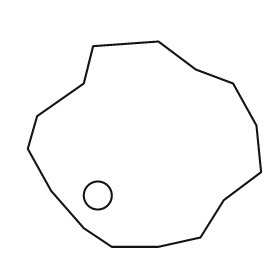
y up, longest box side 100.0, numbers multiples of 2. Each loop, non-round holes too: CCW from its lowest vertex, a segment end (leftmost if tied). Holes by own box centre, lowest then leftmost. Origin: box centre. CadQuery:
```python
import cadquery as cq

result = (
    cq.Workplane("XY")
    .moveTo(-14.0, -44.0)
    .lineTo(6.0, -44.0)
    .lineTo(24.0, -40.0)
    .lineTo(34.0, -24.0)
    .lineTo(50.0, -12.0)
    .lineTo(48.0, 8.0)
    .lineTo(38.0, 26.0)
    .lineTo(22.0, 32.0)
    .lineTo(6.0, 44.0)
    .lineTo(-22.0, 42.0)
    .lineTo(-26.0, 26.0)
    .lineTo(-46.0, 12.0)
    .lineTo(-50.0, -2.0)
    .lineTo(-40.0, -20.0)
    .lineTo(-26.0, -36.0)
    .close()
    .moveTo(-20.0, -22.0)
    .circle(6.0)
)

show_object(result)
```